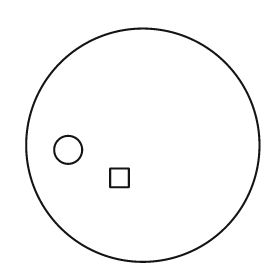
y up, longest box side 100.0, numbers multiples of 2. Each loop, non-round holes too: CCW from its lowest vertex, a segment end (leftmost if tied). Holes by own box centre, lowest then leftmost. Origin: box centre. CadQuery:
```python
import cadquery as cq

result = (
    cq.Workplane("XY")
    .moveTo(0.0, 0.0)
    .circle(50.0)
    .moveTo(-14.0, -18.0)
    .lineTo(-6.0, -18.0)
    .lineTo(-6.0, -10.0)
    .lineTo(-14.0, -10.0)
    .close()
    .moveTo(-32.0, -2.0)
    .circle(6.0)
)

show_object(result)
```